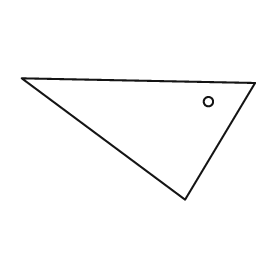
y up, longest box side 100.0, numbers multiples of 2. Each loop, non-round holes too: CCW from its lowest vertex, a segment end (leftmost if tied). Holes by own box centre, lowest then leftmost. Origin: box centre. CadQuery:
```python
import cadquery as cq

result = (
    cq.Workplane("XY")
    .moveTo(20.0, -26.0)
    .lineTo(50.0, 24.0)
    .lineTo(-50.0, 26.0)
    .close()
    .moveTo(30.0, 16.0)
    .circle(2.0)
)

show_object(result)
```